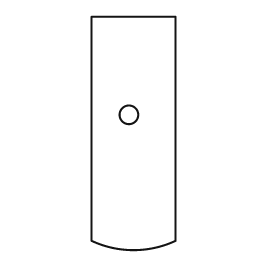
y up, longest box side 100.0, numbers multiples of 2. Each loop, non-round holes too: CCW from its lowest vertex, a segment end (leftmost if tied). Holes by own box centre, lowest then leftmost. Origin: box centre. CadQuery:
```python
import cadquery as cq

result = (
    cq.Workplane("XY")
    .moveTo(-18.0, -46.0)
    .threePointArc((0.0, -50.0), (18.0, -46.0))
    .lineTo(18.0, 50.0)
    .lineTo(-18.0, 50.0)
    .close()
    .moveTo(-2.0, 8.0)
    .circle(4.0)
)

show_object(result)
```